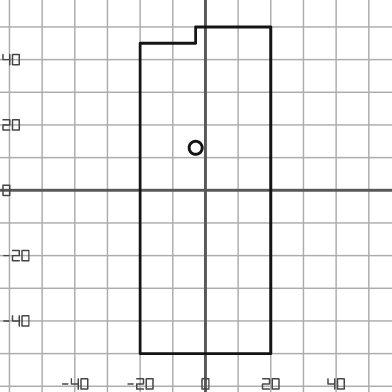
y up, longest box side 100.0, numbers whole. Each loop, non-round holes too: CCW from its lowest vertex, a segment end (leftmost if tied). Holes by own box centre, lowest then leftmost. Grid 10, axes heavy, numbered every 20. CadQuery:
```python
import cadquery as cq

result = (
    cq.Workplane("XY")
    .moveTo(-20.0, -50.0)
    .lineTo(20.0, -50.0)
    .lineTo(20.0, 50.0)
    .lineTo(-3.0, 50.0)
    .lineTo(-3.0, 45.0)
    .lineTo(-20.0, 45.0)
    .close()
    .moveTo(-3.0, 13.0)
    .circle(2.0)
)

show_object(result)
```